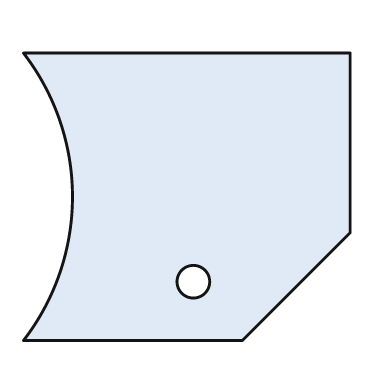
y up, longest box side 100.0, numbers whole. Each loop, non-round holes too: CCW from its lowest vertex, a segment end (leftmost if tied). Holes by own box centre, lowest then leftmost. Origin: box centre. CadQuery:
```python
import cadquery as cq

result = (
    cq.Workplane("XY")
    .moveTo(-50.0, -44.0)
    .lineTo(17.0, -44.0)
    .lineTo(50.0, -11.0)
    .lineTo(50.0, 44.0)
    .lineTo(-50.0, 44.0)
    .threePointArc((-35.0, 0.0), (-50.0, -44.0))
    .close()
    .moveTo(2.0, -26.0)
    .circle(5.0)
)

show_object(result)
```